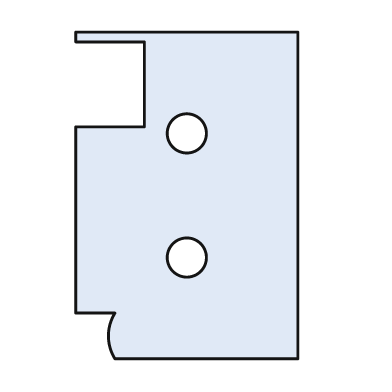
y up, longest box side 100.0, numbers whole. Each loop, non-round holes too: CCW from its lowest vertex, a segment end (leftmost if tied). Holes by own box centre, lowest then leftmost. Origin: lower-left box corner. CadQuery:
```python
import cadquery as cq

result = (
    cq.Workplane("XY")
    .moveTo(12.0, 0.0)
    .lineTo(68.0, 0.0)
    .lineTo(68.0, 100.0)
    .lineTo(0.0, 100.0)
    .lineTo(0.0, 97.0)
    .lineTo(21.0, 97.0)
    .lineTo(21.0, 71.0)
    .lineTo(0.0, 71.0)
    .lineTo(0.0, 14.0)
    .lineTo(12.0, 14.0)
    .threePointArc((10.0, 7.0), (12.0, 0.0))
    .close()
    .moveTo(34.0, 31.0)
    .circle(6.0)
    .moveTo(34.0, 69.0)
    .circle(6.0)
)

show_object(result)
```